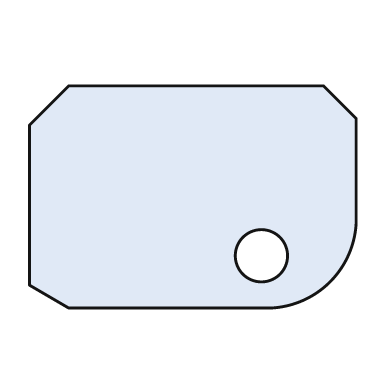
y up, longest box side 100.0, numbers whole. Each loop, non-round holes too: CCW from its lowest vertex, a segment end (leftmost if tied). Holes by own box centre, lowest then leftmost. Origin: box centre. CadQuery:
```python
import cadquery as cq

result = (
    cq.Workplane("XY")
    .moveTo(-38.0, -34.0)
    .lineTo(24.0, -34.0)
    .threePointArc((42.0, -26.0), (50.0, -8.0))
    .lineTo(50.0, 24.0)
    .lineTo(40.0, 34.0)
    .lineTo(-38.0, 34.0)
    .lineTo(-50.0, 22.0)
    .lineTo(-50.0, -27.0)
    .close()
    .moveTo(21.0, -18.0)
    .circle(8.0)
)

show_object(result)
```